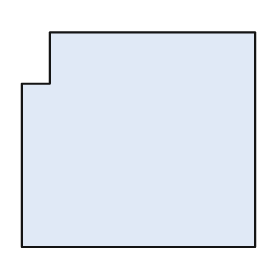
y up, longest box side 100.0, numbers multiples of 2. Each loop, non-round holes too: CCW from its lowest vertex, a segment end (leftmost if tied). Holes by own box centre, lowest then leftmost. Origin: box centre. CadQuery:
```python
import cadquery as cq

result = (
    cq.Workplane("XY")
    .moveTo(-50.0, -46.0)
    .lineTo(50.0, -46.0)
    .lineTo(50.0, 46.0)
    .lineTo(-38.0, 46.0)
    .lineTo(-38.0, 24.0)
    .lineTo(-50.0, 24.0)
    .close()
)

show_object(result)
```